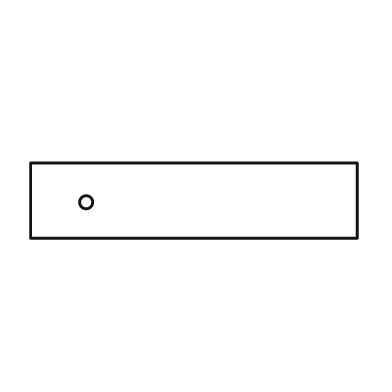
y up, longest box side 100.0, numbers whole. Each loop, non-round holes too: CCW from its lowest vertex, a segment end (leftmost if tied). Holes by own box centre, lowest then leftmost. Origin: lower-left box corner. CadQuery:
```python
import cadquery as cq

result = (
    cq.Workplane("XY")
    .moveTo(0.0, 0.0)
    .lineTo(100.0, 0.0)
    .lineTo(100.0, 23.0)
    .lineTo(0.0, 23.0)
    .close()
    .moveTo(17.0, 11.0)
    .circle(2.0)
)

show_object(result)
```